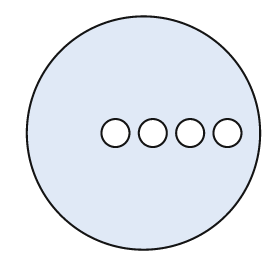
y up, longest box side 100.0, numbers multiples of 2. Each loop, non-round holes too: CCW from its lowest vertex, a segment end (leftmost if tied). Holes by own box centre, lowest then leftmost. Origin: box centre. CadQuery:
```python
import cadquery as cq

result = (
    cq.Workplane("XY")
    .moveTo(0.0, 0.0)
    .circle(50.0)
    .moveTo(-12.0, 0.0)
    .circle(6.0)
    .moveTo(4.0, 0.0)
    .circle(6.0)
    .moveTo(20.0, 0.0)
    .circle(6.0)
    .moveTo(36.0, 0.0)
    .circle(6.0)
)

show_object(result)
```